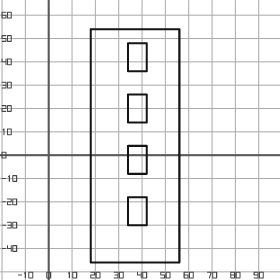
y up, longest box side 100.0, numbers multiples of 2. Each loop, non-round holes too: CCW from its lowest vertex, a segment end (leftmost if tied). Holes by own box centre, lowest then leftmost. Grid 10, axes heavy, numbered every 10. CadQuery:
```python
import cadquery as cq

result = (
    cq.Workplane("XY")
    .moveTo(18.0, -46.0)
    .lineTo(56.0, -46.0)
    .lineTo(56.0, 54.0)
    .lineTo(18.0, 54.0)
    .close()
    .moveTo(34.0, -30.0)
    .lineTo(42.0, -30.0)
    .lineTo(42.0, -18.0)
    .lineTo(34.0, -18.0)
    .close()
    .moveTo(34.0, -8.0)
    .lineTo(42.0, -8.0)
    .lineTo(42.0, 4.0)
    .lineTo(34.0, 4.0)
    .close()
    .moveTo(34.0, 14.0)
    .lineTo(42.0, 14.0)
    .lineTo(42.0, 26.0)
    .lineTo(34.0, 26.0)
    .close()
    .moveTo(34.0, 36.0)
    .lineTo(42.0, 36.0)
    .lineTo(42.0, 48.0)
    .lineTo(34.0, 48.0)
    .close()
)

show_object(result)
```